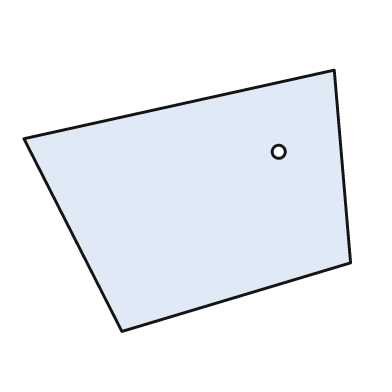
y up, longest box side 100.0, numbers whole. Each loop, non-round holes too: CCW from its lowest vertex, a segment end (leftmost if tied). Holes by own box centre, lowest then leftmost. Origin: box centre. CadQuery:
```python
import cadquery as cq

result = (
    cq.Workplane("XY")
    .moveTo(-20.0, -40.0)
    .lineTo(50.0, -19.0)
    .lineTo(45.0, 40.0)
    .lineTo(-50.0, 19.0)
    .close()
    .moveTo(28.0, 15.0)
    .circle(2.0)
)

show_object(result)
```